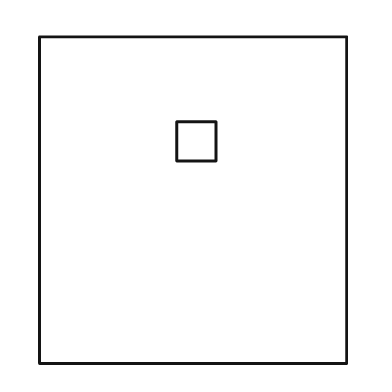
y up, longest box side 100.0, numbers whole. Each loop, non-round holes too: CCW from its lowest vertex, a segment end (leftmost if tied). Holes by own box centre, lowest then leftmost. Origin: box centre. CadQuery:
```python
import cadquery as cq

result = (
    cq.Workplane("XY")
    .moveTo(-47.0, -50.0)
    .lineTo(47.0, -50.0)
    .lineTo(47.0, 50.0)
    .lineTo(-47.0, 50.0)
    .close()
    .moveTo(-5.0, 12.0)
    .lineTo(7.0, 12.0)
    .lineTo(7.0, 24.0)
    .lineTo(-5.0, 24.0)
    .close()
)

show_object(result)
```